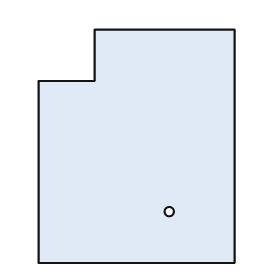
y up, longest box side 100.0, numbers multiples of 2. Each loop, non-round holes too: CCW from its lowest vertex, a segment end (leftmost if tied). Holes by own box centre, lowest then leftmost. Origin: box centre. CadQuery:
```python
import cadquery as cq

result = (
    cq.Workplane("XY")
    .moveTo(-42.0, -50.0)
    .lineTo(42.0, -50.0)
    .lineTo(42.0, 50.0)
    .lineTo(-18.0, 50.0)
    .lineTo(-18.0, 28.0)
    .lineTo(-42.0, 28.0)
    .close()
    .moveTo(14.0, -28.0)
    .circle(2.0)
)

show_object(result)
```